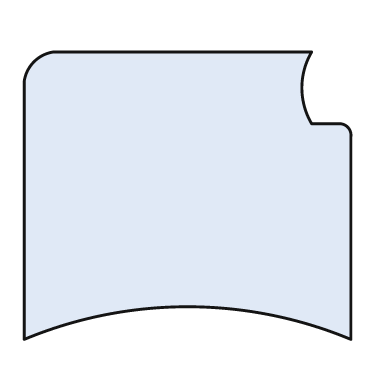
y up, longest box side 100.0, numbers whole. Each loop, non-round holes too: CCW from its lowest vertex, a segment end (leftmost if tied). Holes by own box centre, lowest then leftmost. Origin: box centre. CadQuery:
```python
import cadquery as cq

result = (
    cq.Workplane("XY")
    .moveTo(-50.0, -44.0)
    .threePointArc((0.0, -34.0), (50.0, -44.0))
    .lineTo(50.0, 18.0)
    .threePointArc((49.0, 21.0), (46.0, 22.0))
    .lineTo(38.0, 22.0)
    .threePointArc((35.0, 33.0), (38.0, 44.0))
    .lineTo(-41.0, 44.0)
    .threePointArc((-47.0, 41.0), (-50.0, 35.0))
    .close()
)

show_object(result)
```